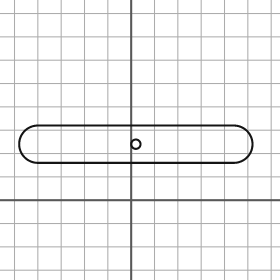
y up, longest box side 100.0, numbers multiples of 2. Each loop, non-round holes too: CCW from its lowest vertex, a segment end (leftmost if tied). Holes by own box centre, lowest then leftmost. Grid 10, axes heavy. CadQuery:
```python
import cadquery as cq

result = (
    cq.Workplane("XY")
    .moveTo(-40.0, 16.0)
    .lineTo(44.0, 16.0)
    .threePointArc((52.0, 24.0), (44.0, 32.0))
    .lineTo(-40.0, 32.0)
    .threePointArc((-48.0, 24.0), (-40.0, 16.0))
    .close()
    .moveTo(2.0, 24.0)
    .circle(2.0)
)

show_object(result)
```